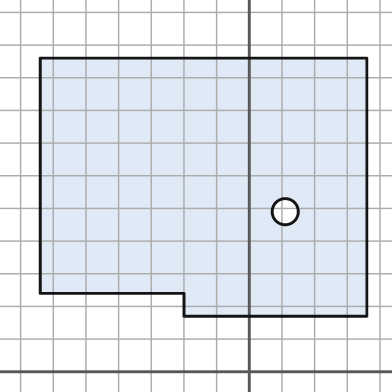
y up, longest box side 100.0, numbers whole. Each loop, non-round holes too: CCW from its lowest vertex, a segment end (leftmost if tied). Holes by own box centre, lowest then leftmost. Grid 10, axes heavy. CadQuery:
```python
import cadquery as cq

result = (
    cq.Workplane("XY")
    .moveTo(-20.0, 17.0)
    .lineTo(36.0, 17.0)
    .lineTo(36.0, 96.0)
    .lineTo(-64.0, 96.0)
    .lineTo(-64.0, 24.0)
    .lineTo(-20.0, 24.0)
    .close()
    .moveTo(11.0, 49.0)
    .circle(4.0)
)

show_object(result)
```